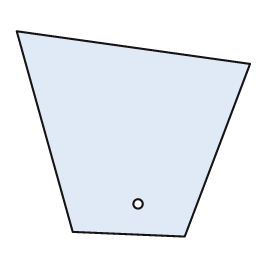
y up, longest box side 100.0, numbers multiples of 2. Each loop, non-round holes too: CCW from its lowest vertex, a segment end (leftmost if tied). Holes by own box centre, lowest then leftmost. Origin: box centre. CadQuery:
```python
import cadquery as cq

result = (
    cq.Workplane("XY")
    .moveTo(22.0, -44.0)
    .lineTo(50.0, 30.0)
    .lineTo(-50.0, 44.0)
    .lineTo(-26.0, -42.0)
    .close()
    .moveTo(2.0, -30.0)
    .circle(2.0)
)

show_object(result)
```